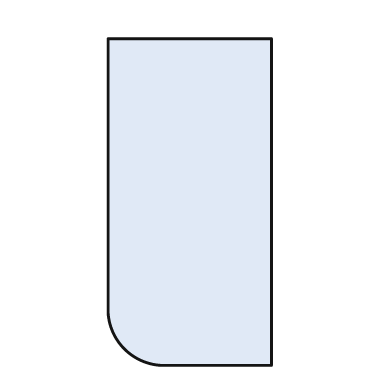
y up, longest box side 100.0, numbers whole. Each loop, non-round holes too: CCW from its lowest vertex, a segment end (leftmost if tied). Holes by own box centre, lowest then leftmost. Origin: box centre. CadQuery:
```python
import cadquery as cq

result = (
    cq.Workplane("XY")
    .moveTo(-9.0, -50.0)
    .lineTo(25.0, -50.0)
    .lineTo(25.0, 50.0)
    .lineTo(-25.0, 50.0)
    .lineTo(-25.0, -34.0)
    .threePointArc((-20.0, -45.0), (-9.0, -50.0))
    .close()
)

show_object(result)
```